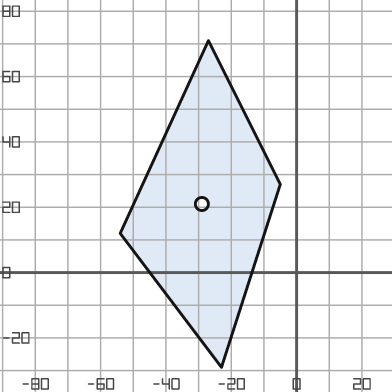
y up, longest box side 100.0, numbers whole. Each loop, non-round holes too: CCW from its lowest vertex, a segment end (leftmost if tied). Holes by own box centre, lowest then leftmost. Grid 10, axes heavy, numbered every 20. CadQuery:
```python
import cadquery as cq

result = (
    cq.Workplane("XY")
    .moveTo(-23.0, -29.0)
    .lineTo(-5.0, 27.0)
    .lineTo(-27.0, 71.0)
    .lineTo(-54.0, 12.0)
    .close()
    .moveTo(-29.0, 21.0)
    .circle(2.0)
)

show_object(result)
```